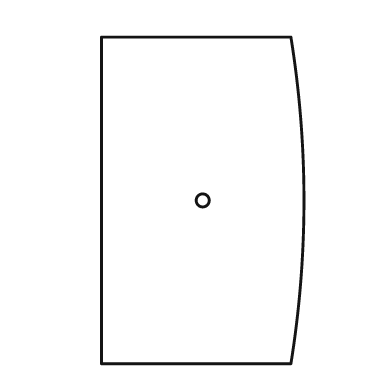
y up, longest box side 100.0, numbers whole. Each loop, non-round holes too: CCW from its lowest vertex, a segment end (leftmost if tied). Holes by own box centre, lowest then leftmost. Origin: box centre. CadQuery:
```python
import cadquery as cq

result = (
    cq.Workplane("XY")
    .moveTo(-31.0, -50.0)
    .lineTo(27.0, -50.0)
    .threePointArc((31.0, 0.0), (27.0, 50.0))
    .lineTo(-31.0, 50.0)
    .close()
    .moveTo(0.0, 0.0)
    .circle(2.0)
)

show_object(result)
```